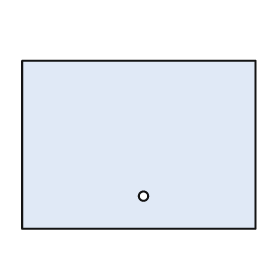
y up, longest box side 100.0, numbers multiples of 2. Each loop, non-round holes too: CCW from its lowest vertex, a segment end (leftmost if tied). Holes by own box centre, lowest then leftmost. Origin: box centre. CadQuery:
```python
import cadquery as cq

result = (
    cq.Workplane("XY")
    .moveTo(-50.0, -36.0)
    .lineTo(50.0, -36.0)
    .lineTo(50.0, 36.0)
    .lineTo(-50.0, 36.0)
    .close()
    .moveTo(2.0, -22.0)
    .circle(2.0)
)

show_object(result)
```